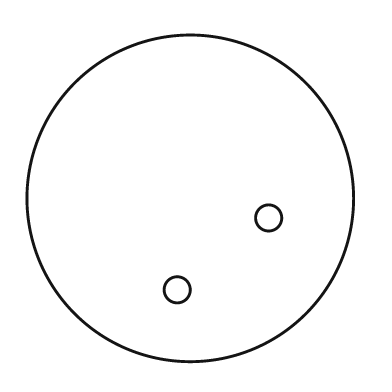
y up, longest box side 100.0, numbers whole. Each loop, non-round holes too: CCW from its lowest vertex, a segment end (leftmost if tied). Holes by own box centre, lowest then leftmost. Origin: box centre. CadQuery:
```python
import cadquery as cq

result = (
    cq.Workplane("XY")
    .moveTo(0.0, 0.0)
    .circle(50.0)
    .moveTo(-4.0, -28.0)
    .circle(4.0)
    .moveTo(24.0, -6.0)
    .circle(4.0)
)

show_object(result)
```